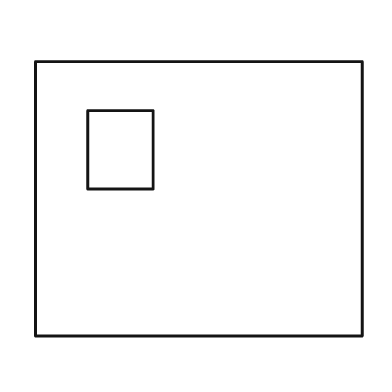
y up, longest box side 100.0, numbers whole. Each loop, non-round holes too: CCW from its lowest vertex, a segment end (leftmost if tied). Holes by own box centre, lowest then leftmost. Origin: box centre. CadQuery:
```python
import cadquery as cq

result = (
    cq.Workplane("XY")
    .moveTo(-50.0, -42.0)
    .lineTo(50.0, -42.0)
    .lineTo(50.0, 42.0)
    .lineTo(-50.0, 42.0)
    .close()
    .moveTo(-34.0, 3.0)
    .lineTo(-14.0, 3.0)
    .lineTo(-14.0, 27.0)
    .lineTo(-34.0, 27.0)
    .close()
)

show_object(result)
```